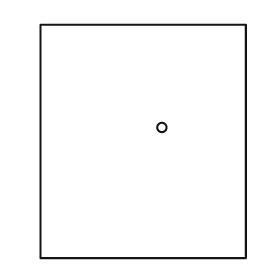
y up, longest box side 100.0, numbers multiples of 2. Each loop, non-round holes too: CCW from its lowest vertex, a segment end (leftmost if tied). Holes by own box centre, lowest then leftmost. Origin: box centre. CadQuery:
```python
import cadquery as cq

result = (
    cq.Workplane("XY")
    .moveTo(-44.0, -50.0)
    .lineTo(44.0, -50.0)
    .lineTo(44.0, 50.0)
    .lineTo(-44.0, 50.0)
    .close()
    .moveTo(8.0, 6.0)
    .circle(2.0)
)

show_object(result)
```